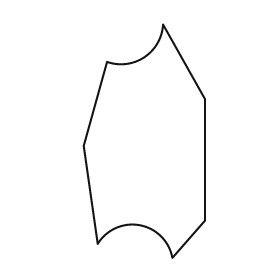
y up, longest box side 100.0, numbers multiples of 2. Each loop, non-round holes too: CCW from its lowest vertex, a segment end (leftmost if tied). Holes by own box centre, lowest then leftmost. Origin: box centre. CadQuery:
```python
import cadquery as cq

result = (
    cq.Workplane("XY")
    .moveTo(12.0, -50.0)
    .lineTo(26.0, -34.0)
    .lineTo(26.0, 18.0)
    .lineTo(8.0, 50.0)
    .threePointArc((0.0, 36.0), (-16.0, 34.0))
    .lineTo(-26.0, -2.0)
    .lineTo(-20.0, -44.0)
    .threePointArc((-2.0, -36.0), (12.0, -50.0))
    .close()
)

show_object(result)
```